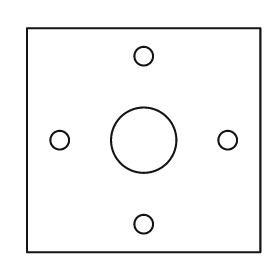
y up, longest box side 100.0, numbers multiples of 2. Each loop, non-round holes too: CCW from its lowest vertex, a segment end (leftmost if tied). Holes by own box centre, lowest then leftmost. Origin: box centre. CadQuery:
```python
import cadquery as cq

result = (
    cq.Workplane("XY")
    .moveTo(-50.0, -48.0)
    .lineTo(50.0, -48.0)
    .lineTo(50.0, 48.0)
    .lineTo(-50.0, 48.0)
    .close()
    .moveTo(0.0, -36.0)
    .circle(4.0)
    .moveTo(-36.0, 0.0)
    .circle(4.0)
    .moveTo(0.0, 0.0)
    .circle(14.0)
    .moveTo(36.0, 0.0)
    .circle(4.0)
    .moveTo(0.0, 36.0)
    .circle(4.0)
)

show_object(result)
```